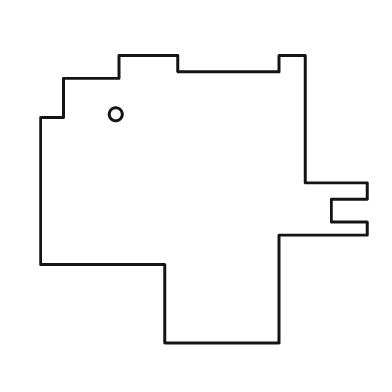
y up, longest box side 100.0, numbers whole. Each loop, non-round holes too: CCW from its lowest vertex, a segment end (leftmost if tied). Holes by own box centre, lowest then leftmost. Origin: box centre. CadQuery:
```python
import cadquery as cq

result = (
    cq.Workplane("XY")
    .moveTo(-12.0, -44.0)
    .lineTo(23.0, -44.0)
    .lineTo(23.0, -11.0)
    .lineTo(50.0, -11.0)
    .lineTo(50.0, -7.0)
    .lineTo(39.0, -7.0)
    .lineTo(39.0, 0.0)
    .lineTo(50.0, 0.0)
    .lineTo(50.0, 5.0)
    .lineTo(31.0, 5.0)
    .lineTo(31.0, 44.0)
    .lineTo(23.0, 44.0)
    .lineTo(23.0, 39.0)
    .lineTo(-8.0, 39.0)
    .lineTo(-8.0, 44.0)
    .lineTo(-26.0, 44.0)
    .lineTo(-26.0, 37.0)
    .lineTo(-43.0, 37.0)
    .lineTo(-43.0, 25.0)
    .lineTo(-50.0, 25.0)
    .lineTo(-50.0, -20.0)
    .lineTo(-12.0, -20.0)
    .close()
    .moveTo(-27.0, 26.0)
    .circle(2.0)
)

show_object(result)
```